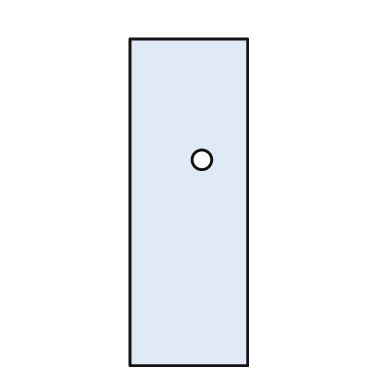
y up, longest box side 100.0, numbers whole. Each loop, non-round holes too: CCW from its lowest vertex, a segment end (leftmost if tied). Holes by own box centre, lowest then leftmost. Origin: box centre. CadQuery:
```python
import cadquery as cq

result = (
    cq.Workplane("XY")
    .moveTo(-18.0, -50.0)
    .lineTo(18.0, -50.0)
    .lineTo(18.0, 50.0)
    .lineTo(-18.0, 50.0)
    .close()
    .moveTo(4.0, 13.0)
    .circle(3.0)
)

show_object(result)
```